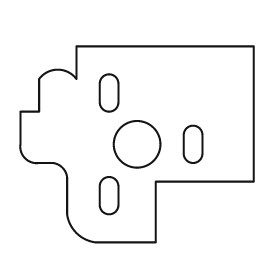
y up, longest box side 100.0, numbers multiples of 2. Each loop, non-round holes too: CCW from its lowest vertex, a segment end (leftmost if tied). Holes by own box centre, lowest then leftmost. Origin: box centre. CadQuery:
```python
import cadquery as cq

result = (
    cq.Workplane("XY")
    .moveTo(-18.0, -42.0)
    .lineTo(8.0, -42.0)
    .lineTo(8.0, -16.0)
    .lineTo(50.0, -16.0)
    .lineTo(50.0, 42.0)
    .lineTo(-26.0, 42.0)
    .lineTo(-26.0, 28.0)
    .threePointArc((-34.0, 32.0), (-42.0, 28.0))
    .lineTo(-42.0, 14.0)
    .lineTo(-50.0, 14.0)
    .lineTo(-50.0, 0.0)
    .threePointArc((-48.0, -6.0), (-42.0, -8.0))
    .lineTo(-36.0, -8.0)
    .threePointArc((-32.0, -10.0), (-30.0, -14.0))
    .lineTo(-30.0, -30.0)
    .threePointArc((-26.0, -38.0), (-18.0, -42.0))
    .close()
    .moveTo(-16.0, -26.0)
    .threePointArc((-12.0, -30.0), (-8.0, -26.0))
    .lineTo(-8.0, -18.0)
    .threePointArc((-12.0, -14.0), (-16.0, -18.0))
    .close()
    .moveTo(0.0, 0.0)
    .circle(10.0)
    .moveTo(20.0, -4.0)
    .threePointArc((24.0, -8.0), (28.0, -4.0))
    .lineTo(28.0, 4.0)
    .threePointArc((24.0, 8.0), (20.0, 4.0))
    .close()
    .moveTo(-16.0, 18.0)
    .threePointArc((-12.0, 14.0), (-8.0, 18.0))
    .lineTo(-8.0, 26.0)
    .threePointArc((-12.0, 30.0), (-16.0, 26.0))
    .close()
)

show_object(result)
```